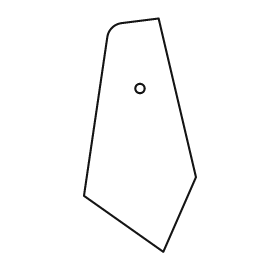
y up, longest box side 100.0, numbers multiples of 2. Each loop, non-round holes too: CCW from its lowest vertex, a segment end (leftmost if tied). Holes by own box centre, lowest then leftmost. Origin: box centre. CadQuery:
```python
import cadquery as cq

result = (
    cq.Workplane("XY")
    .moveTo(10.0, -50.0)
    .lineTo(24.0, -18.0)
    .lineTo(8.0, 50.0)
    .lineTo(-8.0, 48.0)
    .threePointArc((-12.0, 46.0), (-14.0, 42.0))
    .lineTo(-24.0, -26.0)
    .close()
    .moveTo(0.0, 20.0)
    .circle(2.0)
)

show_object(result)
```